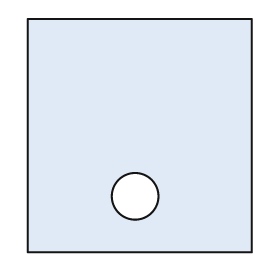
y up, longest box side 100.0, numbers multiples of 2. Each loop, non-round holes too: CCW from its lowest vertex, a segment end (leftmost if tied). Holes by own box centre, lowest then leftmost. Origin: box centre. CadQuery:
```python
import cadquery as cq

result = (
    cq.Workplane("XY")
    .moveTo(-48.0, -50.0)
    .lineTo(48.0, -50.0)
    .lineTo(48.0, 50.0)
    .lineTo(-48.0, 50.0)
    .close()
    .moveTo(-2.0, -26.0)
    .circle(10.0)
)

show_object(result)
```